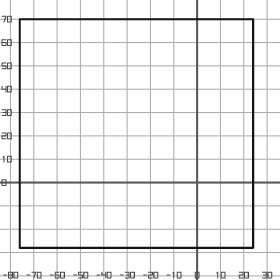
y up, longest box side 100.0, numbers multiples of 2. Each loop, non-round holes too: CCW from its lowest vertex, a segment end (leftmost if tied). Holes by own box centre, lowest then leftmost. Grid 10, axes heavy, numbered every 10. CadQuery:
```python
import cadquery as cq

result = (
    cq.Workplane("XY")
    .moveTo(-76.0, -28.0)
    .lineTo(24.0, -28.0)
    .lineTo(24.0, 70.0)
    .lineTo(-76.0, 70.0)
    .close()
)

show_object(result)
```